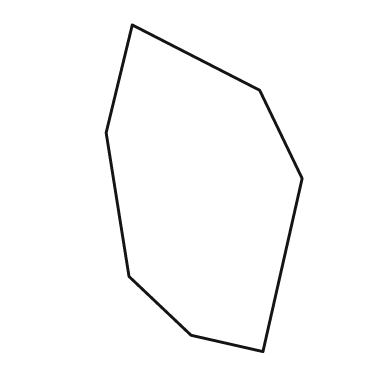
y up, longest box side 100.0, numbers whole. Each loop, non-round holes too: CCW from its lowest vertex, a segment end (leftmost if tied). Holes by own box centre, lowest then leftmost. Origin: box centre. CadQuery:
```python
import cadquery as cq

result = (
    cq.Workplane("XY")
    .moveTo(18.0, -50.0)
    .lineTo(30.0, 3.0)
    .lineTo(17.0, 30.0)
    .lineTo(-22.0, 50.0)
    .lineTo(-30.0, 17.0)
    .lineTo(-23.0, -27.0)
    .lineTo(-4.0, -45.0)
    .close()
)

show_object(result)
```